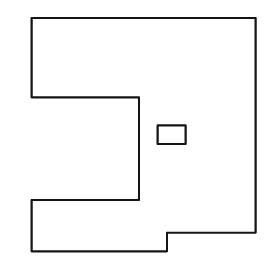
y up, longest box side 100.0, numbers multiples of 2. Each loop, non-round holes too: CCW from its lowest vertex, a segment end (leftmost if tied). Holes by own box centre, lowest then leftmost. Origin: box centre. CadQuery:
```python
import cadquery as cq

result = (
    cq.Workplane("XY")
    .moveTo(-48.0, -50.0)
    .lineTo(10.0, -50.0)
    .lineTo(10.0, -42.0)
    .lineTo(48.0, -42.0)
    .lineTo(48.0, 50.0)
    .lineTo(-48.0, 50.0)
    .lineTo(-48.0, 16.0)
    .lineTo(-2.0, 16.0)
    .lineTo(-2.0, -28.0)
    .lineTo(-48.0, -28.0)
    .close()
    .moveTo(6.0, -4.0)
    .lineTo(18.0, -4.0)
    .lineTo(18.0, 4.0)
    .lineTo(6.0, 4.0)
    .close()
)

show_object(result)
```